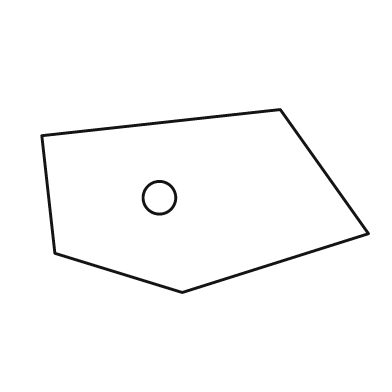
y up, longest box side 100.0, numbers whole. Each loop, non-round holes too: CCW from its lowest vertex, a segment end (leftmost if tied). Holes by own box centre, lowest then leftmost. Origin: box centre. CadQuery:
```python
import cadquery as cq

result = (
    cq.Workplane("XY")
    .moveTo(-7.0, -28.0)
    .lineTo(50.0, -10.0)
    .lineTo(23.0, 28.0)
    .lineTo(-50.0, 20.0)
    .lineTo(-46.0, -16.0)
    .close()
    .moveTo(-14.0, 1.0)
    .circle(5.0)
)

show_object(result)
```